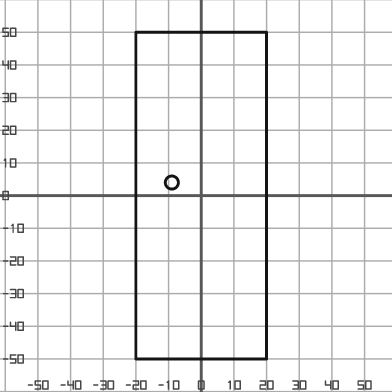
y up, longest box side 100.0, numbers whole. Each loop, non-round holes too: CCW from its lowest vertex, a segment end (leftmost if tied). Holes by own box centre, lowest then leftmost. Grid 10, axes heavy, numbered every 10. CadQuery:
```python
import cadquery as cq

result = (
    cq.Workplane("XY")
    .moveTo(-20.0, -50.0)
    .lineTo(20.0, -50.0)
    .lineTo(20.0, 50.0)
    .lineTo(-20.0, 50.0)
    .close()
    .moveTo(-9.0, 4.0)
    .circle(2.0)
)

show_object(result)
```